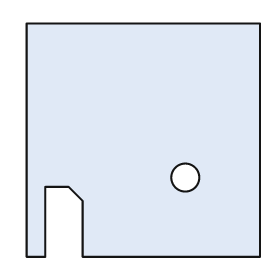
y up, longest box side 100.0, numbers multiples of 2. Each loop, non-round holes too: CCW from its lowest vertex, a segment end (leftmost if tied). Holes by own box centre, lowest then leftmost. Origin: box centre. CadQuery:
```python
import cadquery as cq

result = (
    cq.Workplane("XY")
    .moveTo(-50.0, -50.0)
    .lineTo(-42.0, -50.0)
    .lineTo(-42.0, -20.0)
    .lineTo(-32.0, -20.0)
    .lineTo(-26.0, -26.0)
    .lineTo(-26.0, -50.0)
    .lineTo(50.0, -50.0)
    .lineTo(50.0, 50.0)
    .lineTo(-50.0, 50.0)
    .close()
    .moveTo(18.0, -16.0)
    .circle(6.0)
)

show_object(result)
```